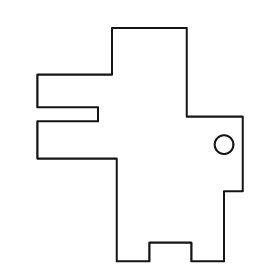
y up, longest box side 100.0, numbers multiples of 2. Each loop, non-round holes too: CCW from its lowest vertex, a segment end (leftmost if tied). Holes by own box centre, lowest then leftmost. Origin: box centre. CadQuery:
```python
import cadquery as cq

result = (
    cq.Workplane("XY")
    .moveTo(-10.0, -50.0)
    .lineTo(4.0, -50.0)
    .lineTo(4.0, -42.0)
    .lineTo(22.0, -42.0)
    .lineTo(22.0, -50.0)
    .lineTo(36.0, -50.0)
    .lineTo(36.0, -20.0)
    .lineTo(44.0, -20.0)
    .lineTo(44.0, 12.0)
    .lineTo(20.0, 12.0)
    .lineTo(20.0, 50.0)
    .lineTo(-12.0, 50.0)
    .lineTo(-12.0, 30.0)
    .lineTo(-44.0, 30.0)
    .lineTo(-44.0, 16.0)
    .lineTo(-18.0, 16.0)
    .lineTo(-18.0, 10.0)
    .lineTo(-44.0, 10.0)
    .lineTo(-44.0, -6.0)
    .lineTo(-10.0, -6.0)
    .close()
    .moveTo(36.0, 0.0)
    .circle(4.0)
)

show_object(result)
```